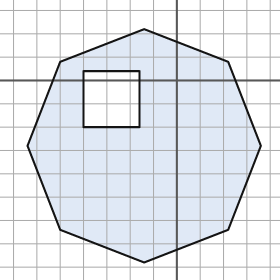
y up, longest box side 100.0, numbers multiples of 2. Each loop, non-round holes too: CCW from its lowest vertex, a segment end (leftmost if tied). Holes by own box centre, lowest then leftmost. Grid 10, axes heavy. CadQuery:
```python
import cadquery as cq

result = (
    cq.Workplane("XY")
    .moveTo(-14.0, -78.0)
    .lineTo(22.0, -64.0)
    .lineTo(36.0, -28.0)
    .lineTo(22.0, 8.0)
    .lineTo(-14.0, 22.0)
    .lineTo(-50.0, 8.0)
    .lineTo(-64.0, -28.0)
    .lineTo(-50.0, -64.0)
    .close()
    .moveTo(-40.0, -20.0)
    .lineTo(-16.0, -20.0)
    .lineTo(-16.0, 4.0)
    .lineTo(-40.0, 4.0)
    .close()
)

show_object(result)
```